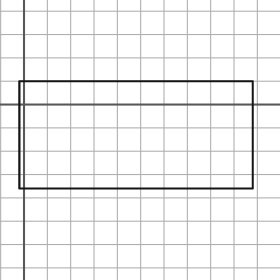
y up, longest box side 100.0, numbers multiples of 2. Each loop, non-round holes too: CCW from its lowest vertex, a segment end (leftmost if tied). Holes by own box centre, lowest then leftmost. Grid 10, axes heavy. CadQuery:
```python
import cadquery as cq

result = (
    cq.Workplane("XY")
    .moveTo(-2.0, -36.0)
    .lineTo(98.0, -36.0)
    .lineTo(98.0, 10.0)
    .lineTo(-2.0, 10.0)
    .close()
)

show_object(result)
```